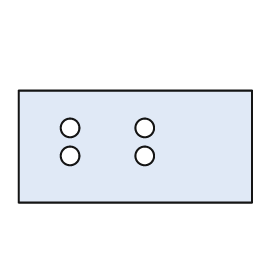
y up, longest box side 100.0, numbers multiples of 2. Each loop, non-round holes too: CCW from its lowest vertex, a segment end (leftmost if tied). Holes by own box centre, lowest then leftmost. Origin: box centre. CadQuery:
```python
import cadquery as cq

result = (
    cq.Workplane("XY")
    .moveTo(-50.0, -24.0)
    .lineTo(50.0, -24.0)
    .lineTo(50.0, 24.0)
    .lineTo(-50.0, 24.0)
    .close()
    .moveTo(-28.0, -4.0)
    .circle(4.0)
    .moveTo(4.0, -4.0)
    .circle(4.0)
    .moveTo(-28.0, 8.0)
    .circle(4.0)
    .moveTo(4.0, 8.0)
    .circle(4.0)
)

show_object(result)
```